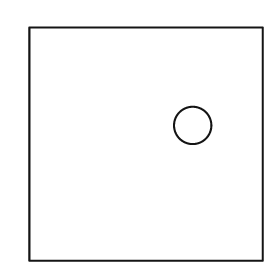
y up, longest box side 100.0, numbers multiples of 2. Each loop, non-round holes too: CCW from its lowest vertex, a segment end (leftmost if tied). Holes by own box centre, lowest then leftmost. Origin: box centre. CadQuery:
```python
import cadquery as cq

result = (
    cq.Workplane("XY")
    .moveTo(-50.0, -50.0)
    .lineTo(50.0, -50.0)
    .lineTo(50.0, 50.0)
    .lineTo(-50.0, 50.0)
    .close()
    .moveTo(20.0, 8.0)
    .circle(8.0)
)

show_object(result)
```